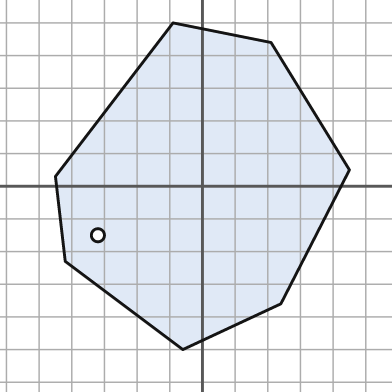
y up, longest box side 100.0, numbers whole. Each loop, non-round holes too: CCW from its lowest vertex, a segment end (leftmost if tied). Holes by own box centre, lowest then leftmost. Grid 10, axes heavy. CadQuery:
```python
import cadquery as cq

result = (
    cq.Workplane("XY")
    .moveTo(-6.0, -50.0)
    .lineTo(24.0, -36.0)
    .lineTo(45.0, 5.0)
    .lineTo(21.0, 44.0)
    .lineTo(-9.0, 50.0)
    .lineTo(-45.0, 3.0)
    .lineTo(-42.0, -23.0)
    .close()
    .moveTo(-32.0, -15.0)
    .circle(2.0)
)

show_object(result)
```